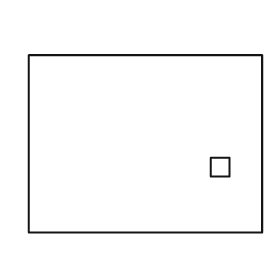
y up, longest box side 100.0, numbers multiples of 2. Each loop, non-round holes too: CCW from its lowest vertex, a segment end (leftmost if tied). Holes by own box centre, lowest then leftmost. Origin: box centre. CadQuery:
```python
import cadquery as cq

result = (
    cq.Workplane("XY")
    .moveTo(-50.0, -38.0)
    .lineTo(50.0, -38.0)
    .lineTo(50.0, 38.0)
    .lineTo(-50.0, 38.0)
    .close()
    .moveTo(28.0, -14.0)
    .lineTo(36.0, -14.0)
    .lineTo(36.0, -6.0)
    .lineTo(28.0, -6.0)
    .close()
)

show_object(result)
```